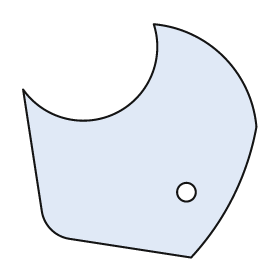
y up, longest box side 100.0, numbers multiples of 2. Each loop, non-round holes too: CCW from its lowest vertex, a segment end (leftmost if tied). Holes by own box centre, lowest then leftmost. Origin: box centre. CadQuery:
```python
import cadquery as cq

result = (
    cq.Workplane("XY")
    .moveTo(22.0, -50.0)
    .threePointArc((40.0, -24.0), (50.0, 6.0))
    .threePointArc((36.0, 36.0), (6.0, 50.0))
    .threePointArc((-10.0, 12.0), (-50.0, 22.0))
    .lineTo(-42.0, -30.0)
    .threePointArc((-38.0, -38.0), (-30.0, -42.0))
    .close()
    .moveTo(20.0, -22.0)
    .circle(4.0)
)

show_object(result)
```